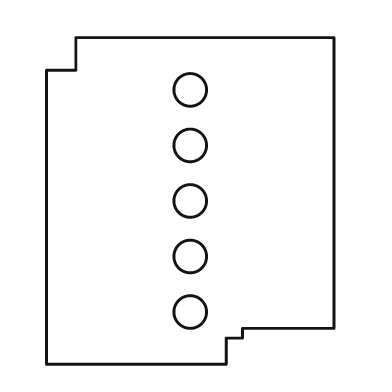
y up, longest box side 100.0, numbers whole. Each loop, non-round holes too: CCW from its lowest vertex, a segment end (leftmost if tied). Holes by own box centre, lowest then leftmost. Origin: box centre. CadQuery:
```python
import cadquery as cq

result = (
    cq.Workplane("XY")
    .moveTo(-44.0, -50.0)
    .lineTo(11.0, -50.0)
    .lineTo(11.0, -42.0)
    .lineTo(16.0, -42.0)
    .lineTo(16.0, -39.0)
    .lineTo(44.0, -39.0)
    .lineTo(44.0, 50.0)
    .lineTo(-35.0, 50.0)
    .lineTo(-35.0, 40.0)
    .lineTo(-44.0, 40.0)
    .close()
    .moveTo(0.0, -34.0)
    .circle(5.0)
    .moveTo(0.0, -17.0)
    .circle(5.0)
    .moveTo(0.0, 0.0)
    .circle(5.0)
    .moveTo(0.0, 17.0)
    .circle(5.0)
    .moveTo(0.0, 34.0)
    .circle(5.0)
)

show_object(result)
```